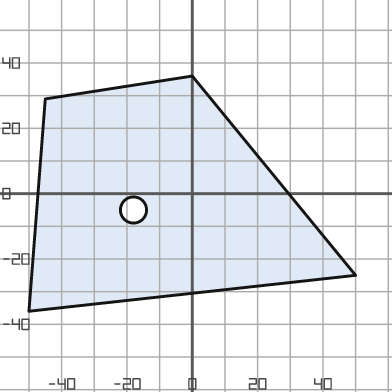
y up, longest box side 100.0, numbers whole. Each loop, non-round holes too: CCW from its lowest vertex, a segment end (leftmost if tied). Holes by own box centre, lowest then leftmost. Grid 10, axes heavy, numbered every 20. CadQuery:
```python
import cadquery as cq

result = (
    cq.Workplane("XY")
    .moveTo(-50.0, -36.0)
    .lineTo(50.0, -25.0)
    .lineTo(0.0, 36.0)
    .lineTo(-45.0, 29.0)
    .close()
    .moveTo(-18.0, -5.0)
    .circle(4.0)
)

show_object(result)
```